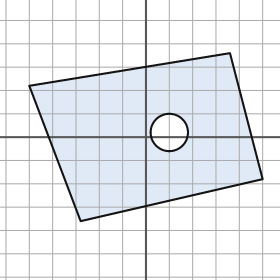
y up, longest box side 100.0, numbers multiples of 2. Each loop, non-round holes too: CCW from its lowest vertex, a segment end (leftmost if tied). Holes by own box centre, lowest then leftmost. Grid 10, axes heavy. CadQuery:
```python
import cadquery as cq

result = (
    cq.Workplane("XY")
    .moveTo(-28.0, -36.0)
    .lineTo(50.0, -18.0)
    .lineTo(36.0, 36.0)
    .lineTo(-50.0, 22.0)
    .close()
    .moveTo(10.0, 2.0)
    .circle(8.0)
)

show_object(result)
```